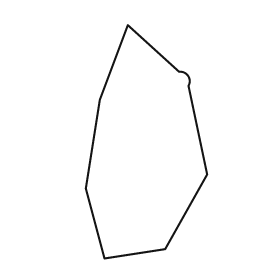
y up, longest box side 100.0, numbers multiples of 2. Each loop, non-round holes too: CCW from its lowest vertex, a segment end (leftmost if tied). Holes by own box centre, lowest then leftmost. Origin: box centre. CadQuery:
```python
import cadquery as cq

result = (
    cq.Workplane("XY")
    .moveTo(-18.0, -50.0)
    .lineTo(8.0, -46.0)
    .lineTo(26.0, -14.0)
    .lineTo(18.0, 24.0)
    .threePointArc((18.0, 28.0), (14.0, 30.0))
    .lineTo(-8.0, 50.0)
    .lineTo(-20.0, 18.0)
    .lineTo(-26.0, -20.0)
    .close()
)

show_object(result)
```